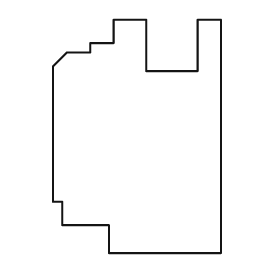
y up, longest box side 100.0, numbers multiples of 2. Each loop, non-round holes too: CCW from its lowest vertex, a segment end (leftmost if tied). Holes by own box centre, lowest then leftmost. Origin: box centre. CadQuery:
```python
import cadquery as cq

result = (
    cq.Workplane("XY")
    .moveTo(-12.0, -50.0)
    .lineTo(36.0, -50.0)
    .lineTo(36.0, 50.0)
    .lineTo(26.0, 50.0)
    .lineTo(26.0, 28.0)
    .lineTo(4.0, 28.0)
    .lineTo(4.0, 50.0)
    .lineTo(-10.0, 50.0)
    .lineTo(-10.0, 40.0)
    .lineTo(-20.0, 40.0)
    .lineTo(-20.0, 36.0)
    .lineTo(-30.0, 36.0)
    .lineTo(-36.0, 30.0)
    .lineTo(-36.0, -28.0)
    .lineTo(-32.0, -28.0)
    .lineTo(-32.0, -38.0)
    .lineTo(-12.0, -38.0)
    .close()
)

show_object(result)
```